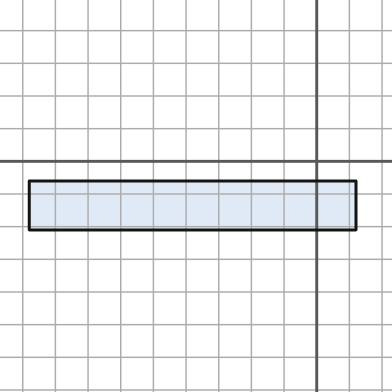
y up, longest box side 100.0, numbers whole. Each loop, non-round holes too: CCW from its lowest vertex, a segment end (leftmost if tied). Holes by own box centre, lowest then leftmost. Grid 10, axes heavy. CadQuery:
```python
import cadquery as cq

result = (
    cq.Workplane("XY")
    .moveTo(-88.0, -21.0)
    .lineTo(12.0, -21.0)
    .lineTo(12.0, -6.0)
    .lineTo(-88.0, -6.0)
    .close()
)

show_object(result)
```